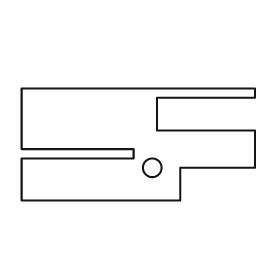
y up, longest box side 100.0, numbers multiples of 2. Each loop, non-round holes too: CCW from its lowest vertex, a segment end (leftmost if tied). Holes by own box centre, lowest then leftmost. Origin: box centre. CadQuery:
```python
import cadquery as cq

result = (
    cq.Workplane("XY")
    .moveTo(-50.0, -24.0)
    .lineTo(18.0, -24.0)
    .lineTo(18.0, -10.0)
    .lineTo(50.0, -10.0)
    .lineTo(50.0, 6.0)
    .lineTo(8.0, 6.0)
    .lineTo(8.0, 20.0)
    .lineTo(50.0, 20.0)
    .lineTo(50.0, 24.0)
    .lineTo(-50.0, 24.0)
    .lineTo(-50.0, -2.0)
    .lineTo(-2.0, -2.0)
    .lineTo(-2.0, -6.0)
    .lineTo(-50.0, -6.0)
    .close()
    .moveTo(6.0, -10.0)
    .circle(4.0)
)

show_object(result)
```